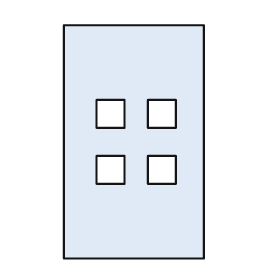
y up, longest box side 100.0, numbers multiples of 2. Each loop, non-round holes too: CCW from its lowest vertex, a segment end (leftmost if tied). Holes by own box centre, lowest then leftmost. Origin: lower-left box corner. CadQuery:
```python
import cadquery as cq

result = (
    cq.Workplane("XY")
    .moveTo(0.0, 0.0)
    .lineTo(60.0, 0.0)
    .lineTo(60.0, 100.0)
    .lineTo(0.0, 100.0)
    .close()
    .moveTo(14.0, 32.0)
    .lineTo(26.0, 32.0)
    .lineTo(26.0, 44.0)
    .lineTo(14.0, 44.0)
    .close()
    .moveTo(36.0, 32.0)
    .lineTo(48.0, 32.0)
    .lineTo(48.0, 44.0)
    .lineTo(36.0, 44.0)
    .close()
    .moveTo(14.0, 56.0)
    .lineTo(26.0, 56.0)
    .lineTo(26.0, 68.0)
    .lineTo(14.0, 68.0)
    .close()
    .moveTo(36.0, 56.0)
    .lineTo(48.0, 56.0)
    .lineTo(48.0, 68.0)
    .lineTo(36.0, 68.0)
    .close()
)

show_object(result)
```